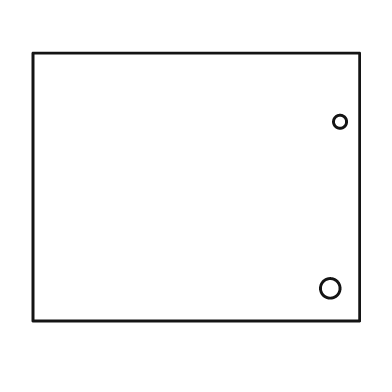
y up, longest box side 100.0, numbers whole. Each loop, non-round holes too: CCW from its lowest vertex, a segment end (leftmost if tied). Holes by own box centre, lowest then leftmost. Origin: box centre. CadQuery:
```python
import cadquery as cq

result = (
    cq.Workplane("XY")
    .moveTo(-50.0, -41.0)
    .lineTo(50.0, -41.0)
    .lineTo(50.0, 41.0)
    .lineTo(-50.0, 41.0)
    .close()
    .moveTo(41.0, -31.0)
    .circle(3.0)
    .moveTo(44.0, 20.0)
    .circle(2.0)
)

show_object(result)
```